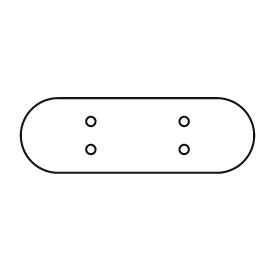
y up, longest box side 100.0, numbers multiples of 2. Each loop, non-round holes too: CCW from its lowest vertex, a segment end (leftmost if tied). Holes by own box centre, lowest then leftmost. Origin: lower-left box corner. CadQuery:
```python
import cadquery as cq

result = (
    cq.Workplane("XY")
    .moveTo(16.0, 0.0)
    .lineTo(84.0, 0.0)
    .threePointArc((100.0, 16.0), (84.0, 32.0))
    .lineTo(16.0, 32.0)
    .threePointArc((0.0, 16.0), (16.0, 0.0))
    .close()
    .moveTo(30.0, 10.0)
    .circle(2.0)
    .moveTo(70.0, 10.0)
    .circle(2.0)
    .moveTo(30.0, 22.0)
    .circle(2.0)
    .moveTo(70.0, 22.0)
    .circle(2.0)
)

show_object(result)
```